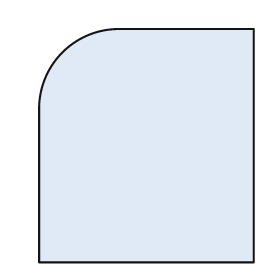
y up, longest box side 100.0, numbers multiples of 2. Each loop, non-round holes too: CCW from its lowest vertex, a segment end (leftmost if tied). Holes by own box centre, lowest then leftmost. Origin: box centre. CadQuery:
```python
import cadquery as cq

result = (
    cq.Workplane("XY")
    .moveTo(-46.0, -50.0)
    .lineTo(46.0, -50.0)
    .lineTo(46.0, 50.0)
    .lineTo(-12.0, 50.0)
    .threePointArc((-36.0, 40.0), (-46.0, 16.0))
    .close()
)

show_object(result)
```